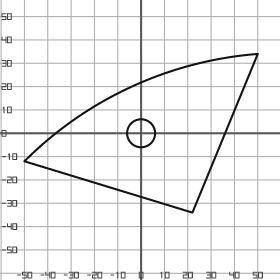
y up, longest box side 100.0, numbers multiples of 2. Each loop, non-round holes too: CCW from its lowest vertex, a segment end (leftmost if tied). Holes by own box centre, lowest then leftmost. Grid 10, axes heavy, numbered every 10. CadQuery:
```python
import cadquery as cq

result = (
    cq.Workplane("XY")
    .moveTo(22.0, -34.0)
    .lineTo(50.0, 34.0)
    .threePointArc((-4.0, 20.0), (-50.0, -12.0))
    .close()
    .moveTo(0.0, 0.0)
    .circle(6.0)
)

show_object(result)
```